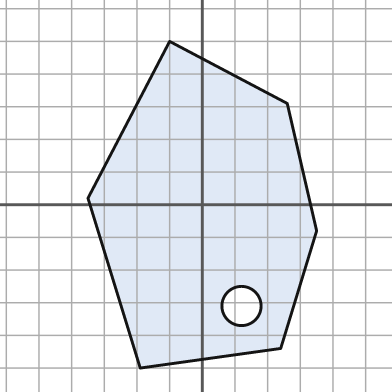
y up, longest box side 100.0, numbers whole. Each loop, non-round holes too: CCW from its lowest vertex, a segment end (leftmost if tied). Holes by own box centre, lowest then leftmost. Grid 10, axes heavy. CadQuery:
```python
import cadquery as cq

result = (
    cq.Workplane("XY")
    .moveTo(-19.0, -50.0)
    .lineTo(24.0, -44.0)
    .lineTo(35.0, -8.0)
    .lineTo(26.0, 31.0)
    .lineTo(-10.0, 50.0)
    .lineTo(-35.0, 2.0)
    .close()
    .moveTo(12.0, -31.0)
    .circle(6.0)
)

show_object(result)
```